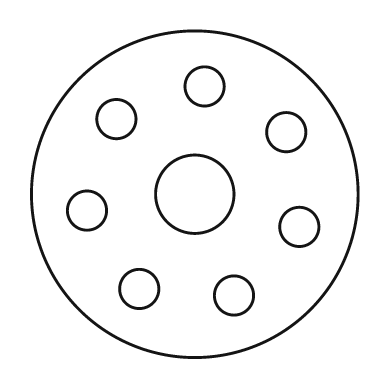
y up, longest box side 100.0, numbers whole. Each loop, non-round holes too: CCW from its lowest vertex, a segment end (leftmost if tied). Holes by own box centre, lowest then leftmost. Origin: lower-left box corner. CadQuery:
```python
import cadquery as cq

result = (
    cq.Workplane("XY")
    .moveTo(50.0, 50.0)
    .circle(50.0)
    .moveTo(62.0, 19.0)
    .circle(6.0)
    .moveTo(33.0, 21.0)
    .circle(6.0)
    .moveTo(82.0, 40.0)
    .circle(6.0)
    .moveTo(17.0, 45.0)
    .circle(6.0)
    .moveTo(50.0, 50.0)
    .circle(12.0)
    .moveTo(78.0, 69.0)
    .circle(6.0)
    .moveTo(26.0, 73.0)
    .circle(6.0)
    .moveTo(53.0, 83.0)
    .circle(6.0)
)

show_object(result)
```